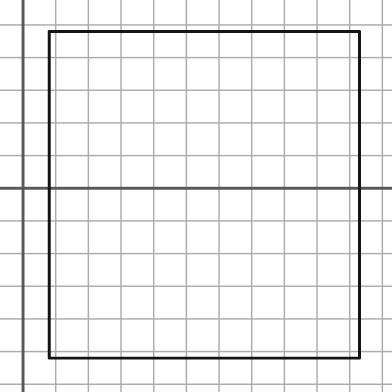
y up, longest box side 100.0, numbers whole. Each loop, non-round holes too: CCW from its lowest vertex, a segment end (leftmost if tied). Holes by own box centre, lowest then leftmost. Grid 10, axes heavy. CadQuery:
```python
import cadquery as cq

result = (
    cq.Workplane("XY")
    .moveTo(8.0, -52.0)
    .lineTo(103.0, -52.0)
    .lineTo(103.0, 48.0)
    .lineTo(8.0, 48.0)
    .close()
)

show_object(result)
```